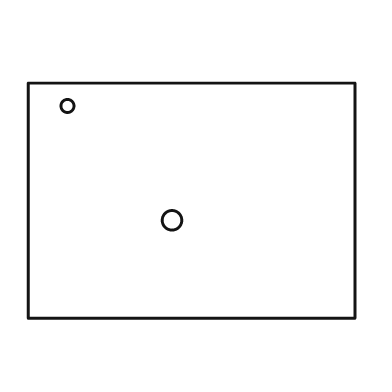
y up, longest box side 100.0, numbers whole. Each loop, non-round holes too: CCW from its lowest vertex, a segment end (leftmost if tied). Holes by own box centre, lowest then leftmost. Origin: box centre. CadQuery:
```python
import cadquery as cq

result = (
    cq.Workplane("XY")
    .moveTo(-50.0, -36.0)
    .lineTo(50.0, -36.0)
    .lineTo(50.0, 36.0)
    .lineTo(-50.0, 36.0)
    .close()
    .moveTo(-6.0, -6.0)
    .circle(3.0)
    .moveTo(-38.0, 29.0)
    .circle(2.0)
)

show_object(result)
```